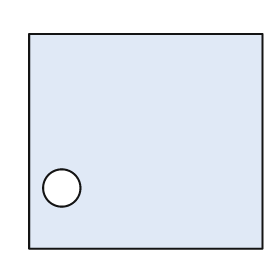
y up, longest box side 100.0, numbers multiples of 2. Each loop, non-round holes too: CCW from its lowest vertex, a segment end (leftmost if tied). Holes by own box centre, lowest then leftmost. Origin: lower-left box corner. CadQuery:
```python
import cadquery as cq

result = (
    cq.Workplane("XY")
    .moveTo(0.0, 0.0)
    .lineTo(100.0, 0.0)
    .lineTo(100.0, 92.0)
    .lineTo(0.0, 92.0)
    .close()
    .moveTo(14.0, 26.0)
    .circle(8.0)
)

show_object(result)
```